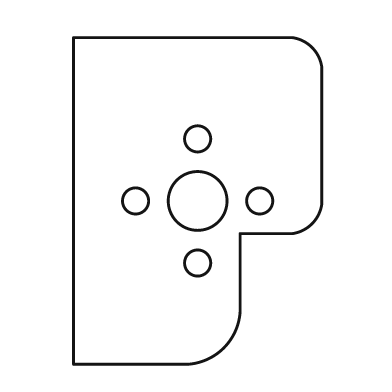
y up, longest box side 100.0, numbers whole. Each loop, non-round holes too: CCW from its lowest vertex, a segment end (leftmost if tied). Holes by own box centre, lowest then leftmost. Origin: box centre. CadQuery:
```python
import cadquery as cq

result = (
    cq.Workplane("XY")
    .moveTo(-38.0, -50.0)
    .lineTo(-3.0, -50.0)
    .threePointArc((8.0, -45.0), (13.0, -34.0))
    .lineTo(13.0, -10.0)
    .lineTo(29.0, -10.0)
    .threePointArc((35.0, -7.0), (38.0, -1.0))
    .lineTo(38.0, 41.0)
    .threePointArc((35.0, 47.0), (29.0, 50.0))
    .lineTo(-38.0, 50.0)
    .close()
    .moveTo(0.0, -19.0)
    .circle(4.0)
    .moveTo(-19.0, 0.0)
    .circle(4.0)
    .moveTo(0.0, 0.0)
    .circle(9.0)
    .moveTo(19.0, 0.0)
    .circle(4.0)
    .moveTo(0.0, 19.0)
    .circle(4.0)
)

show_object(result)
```